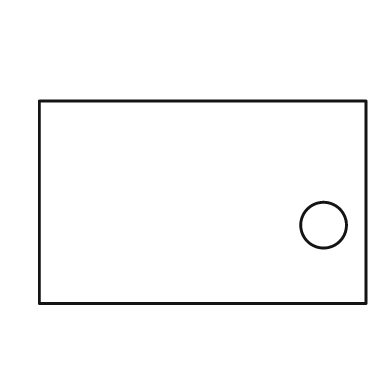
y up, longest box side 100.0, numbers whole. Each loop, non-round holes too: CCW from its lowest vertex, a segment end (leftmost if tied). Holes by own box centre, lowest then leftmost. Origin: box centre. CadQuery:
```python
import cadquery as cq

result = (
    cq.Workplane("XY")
    .moveTo(-50.0, -31.0)
    .lineTo(50.0, -31.0)
    .lineTo(50.0, 31.0)
    .lineTo(-50.0, 31.0)
    .close()
    .moveTo(37.0, -7.0)
    .circle(7.0)
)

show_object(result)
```